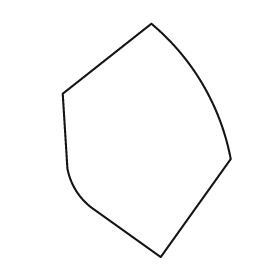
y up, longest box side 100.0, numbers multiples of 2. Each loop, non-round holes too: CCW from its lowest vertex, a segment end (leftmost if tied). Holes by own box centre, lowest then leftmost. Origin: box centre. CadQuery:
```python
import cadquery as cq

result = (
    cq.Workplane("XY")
    .moveTo(6.0, -50.0)
    .lineTo(36.0, -8.0)
    .threePointArc((24.0, 24.0), (2.0, 50.0))
    .lineTo(-36.0, 20.0)
    .lineTo(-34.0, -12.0)
    .threePointArc((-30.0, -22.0), (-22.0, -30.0))
    .close()
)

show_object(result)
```